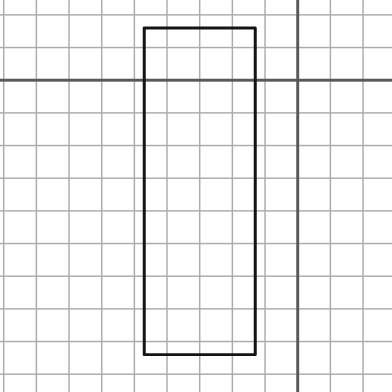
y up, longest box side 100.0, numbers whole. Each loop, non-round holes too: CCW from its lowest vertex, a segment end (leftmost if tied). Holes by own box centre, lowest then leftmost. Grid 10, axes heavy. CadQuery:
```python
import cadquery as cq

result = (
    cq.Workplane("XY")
    .moveTo(-47.0, -84.0)
    .lineTo(-13.0, -84.0)
    .lineTo(-13.0, 16.0)
    .lineTo(-47.0, 16.0)
    .close()
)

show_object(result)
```